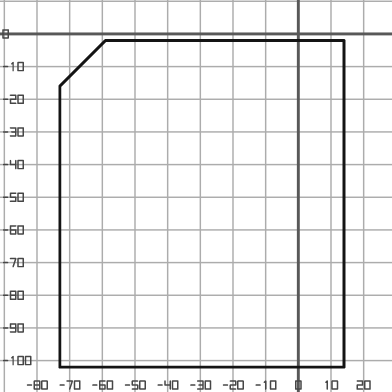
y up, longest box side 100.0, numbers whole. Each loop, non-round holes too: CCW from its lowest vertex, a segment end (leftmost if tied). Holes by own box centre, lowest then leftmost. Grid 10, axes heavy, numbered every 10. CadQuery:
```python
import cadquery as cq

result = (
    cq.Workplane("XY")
    .moveTo(-73.0, -102.0)
    .lineTo(14.0, -102.0)
    .lineTo(14.0, -2.0)
    .lineTo(-59.0, -2.0)
    .lineTo(-73.0, -16.0)
    .close()
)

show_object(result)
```